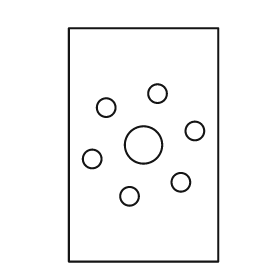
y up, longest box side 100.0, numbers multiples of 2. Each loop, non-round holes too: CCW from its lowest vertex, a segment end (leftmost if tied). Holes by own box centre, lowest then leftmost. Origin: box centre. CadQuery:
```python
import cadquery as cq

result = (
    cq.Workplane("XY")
    .moveTo(-32.0, -50.0)
    .lineTo(32.0, -50.0)
    .lineTo(32.0, 50.0)
    .lineTo(-32.0, 50.0)
    .close()
    .moveTo(-6.0, -22.0)
    .circle(4.0)
    .moveTo(16.0, -16.0)
    .circle(4.0)
    .moveTo(-22.0, -6.0)
    .circle(4.0)
    .moveTo(0.0, 0.0)
    .circle(8.0)
    .moveTo(22.0, 6.0)
    .circle(4.0)
    .moveTo(-16.0, 16.0)
    .circle(4.0)
    .moveTo(6.0, 22.0)
    .circle(4.0)
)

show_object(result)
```